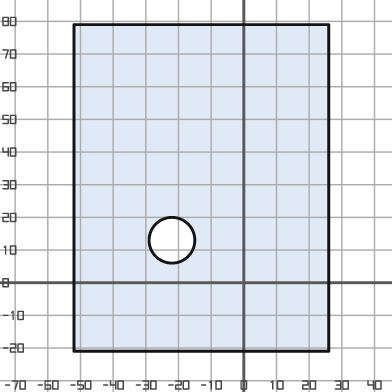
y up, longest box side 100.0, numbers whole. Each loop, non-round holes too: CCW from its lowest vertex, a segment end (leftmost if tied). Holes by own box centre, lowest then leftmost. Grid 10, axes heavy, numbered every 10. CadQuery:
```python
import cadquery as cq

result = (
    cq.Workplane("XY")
    .moveTo(-52.0, -21.0)
    .lineTo(26.0, -21.0)
    .lineTo(26.0, 79.0)
    .lineTo(-52.0, 79.0)
    .close()
    .moveTo(-22.0, 13.0)
    .circle(7.0)
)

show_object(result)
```